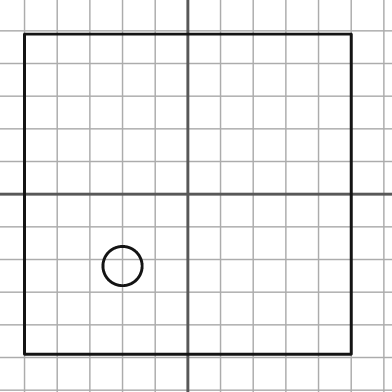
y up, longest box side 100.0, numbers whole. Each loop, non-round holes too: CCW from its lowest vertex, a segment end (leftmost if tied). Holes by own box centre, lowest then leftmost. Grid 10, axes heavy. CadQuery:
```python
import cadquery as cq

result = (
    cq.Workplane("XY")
    .moveTo(-50.0, -49.0)
    .lineTo(50.0, -49.0)
    .lineTo(50.0, 49.0)
    .lineTo(-50.0, 49.0)
    .close()
    .moveTo(-20.0, -22.0)
    .circle(6.0)
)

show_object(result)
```